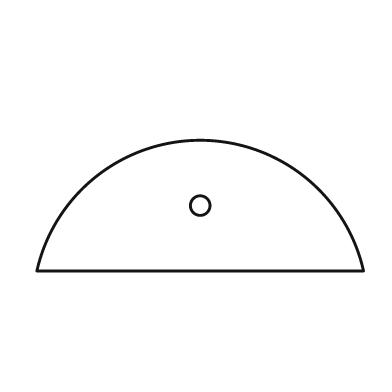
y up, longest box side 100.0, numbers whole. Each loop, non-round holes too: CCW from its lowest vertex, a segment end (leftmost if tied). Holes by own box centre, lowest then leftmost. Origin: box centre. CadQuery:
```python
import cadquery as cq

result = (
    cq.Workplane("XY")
    .moveTo(-50.0, -20.0)
    .lineTo(50.0, -20.0)
    .threePointArc((0.0, 20.0), (-50.0, -20.0))
    .close()
    .moveTo(0.0, 0.0)
    .circle(3.0)
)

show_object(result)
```